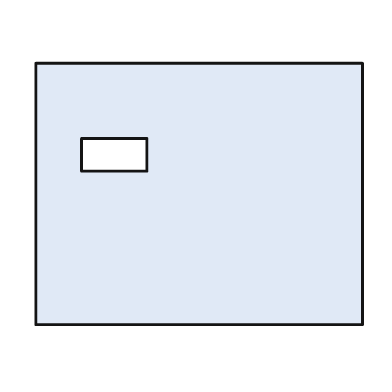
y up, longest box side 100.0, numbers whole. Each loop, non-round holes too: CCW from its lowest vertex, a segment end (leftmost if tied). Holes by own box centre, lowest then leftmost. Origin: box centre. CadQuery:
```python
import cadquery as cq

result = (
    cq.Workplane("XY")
    .moveTo(-50.0, -40.0)
    .lineTo(50.0, -40.0)
    .lineTo(50.0, 40.0)
    .lineTo(-50.0, 40.0)
    .close()
    .moveTo(-36.0, 7.0)
    .lineTo(-16.0, 7.0)
    .lineTo(-16.0, 17.0)
    .lineTo(-36.0, 17.0)
    .close()
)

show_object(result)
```